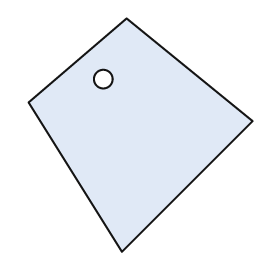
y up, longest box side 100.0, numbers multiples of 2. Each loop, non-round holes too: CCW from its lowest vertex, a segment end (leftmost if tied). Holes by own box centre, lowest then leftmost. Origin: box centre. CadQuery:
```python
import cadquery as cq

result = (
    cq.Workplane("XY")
    .moveTo(-8.0, -50.0)
    .lineTo(48.0, 6.0)
    .lineTo(-6.0, 50.0)
    .lineTo(-48.0, 14.0)
    .close()
    .moveTo(-16.0, 24.0)
    .circle(4.0)
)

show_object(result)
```